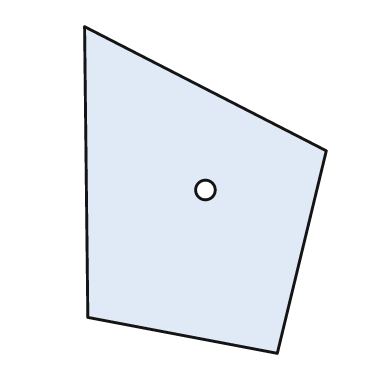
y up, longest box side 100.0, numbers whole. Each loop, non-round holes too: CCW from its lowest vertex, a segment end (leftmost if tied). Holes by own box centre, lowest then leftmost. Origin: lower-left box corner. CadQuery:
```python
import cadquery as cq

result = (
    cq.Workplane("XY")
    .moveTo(59.0, 0.0)
    .lineTo(74.0, 62.0)
    .lineTo(0.0, 100.0)
    .lineTo(1.0, 11.0)
    .close()
    .moveTo(37.0, 50.0)
    .circle(3.0)
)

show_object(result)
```